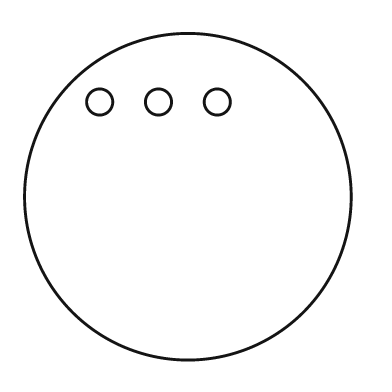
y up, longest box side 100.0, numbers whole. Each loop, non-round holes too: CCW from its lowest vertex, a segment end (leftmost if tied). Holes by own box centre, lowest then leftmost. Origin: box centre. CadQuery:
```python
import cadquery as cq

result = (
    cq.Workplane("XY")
    .moveTo(0.0, 0.0)
    .circle(50.0)
    .moveTo(-27.0, 29.0)
    .circle(4.0)
    .moveTo(-9.0, 29.0)
    .circle(4.0)
    .moveTo(9.0, 29.0)
    .circle(4.0)
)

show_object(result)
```